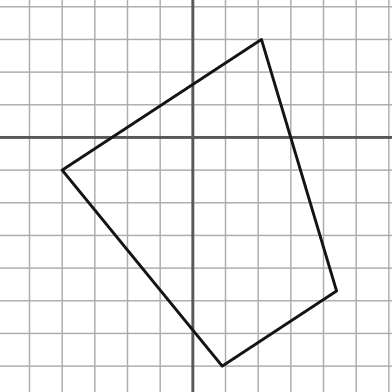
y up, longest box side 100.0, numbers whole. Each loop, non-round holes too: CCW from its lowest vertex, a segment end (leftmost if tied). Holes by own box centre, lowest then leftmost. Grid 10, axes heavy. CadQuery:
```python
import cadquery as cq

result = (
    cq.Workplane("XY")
    .moveTo(9.0, -70.0)
    .lineTo(44.0, -47.0)
    .lineTo(21.0, 30.0)
    .lineTo(-40.0, -10.0)
    .close()
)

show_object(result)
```